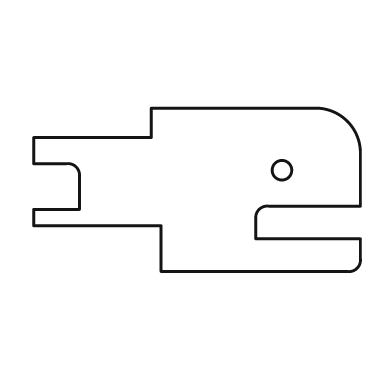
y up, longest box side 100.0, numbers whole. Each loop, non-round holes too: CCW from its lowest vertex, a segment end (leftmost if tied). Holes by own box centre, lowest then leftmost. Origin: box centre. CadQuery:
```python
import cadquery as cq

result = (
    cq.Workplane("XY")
    .moveTo(-11.0, -25.0)
    .lineTo(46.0, -25.0)
    .threePointArc((49.0, -24.0), (50.0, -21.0))
    .lineTo(50.0, -15.0)
    .lineTo(18.0, -15.0)
    .lineTo(18.0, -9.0)
    .threePointArc((19.0, -6.0), (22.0, -5.0))
    .lineTo(50.0, -5.0)
    .lineTo(50.0, 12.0)
    .threePointArc((46.0, 21.0), (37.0, 25.0))
    .lineTo(-14.0, 25.0)
    .lineTo(-14.0, 16.0)
    .lineTo(-50.0, 16.0)
    .lineTo(-50.0, 8.0)
    .lineTo(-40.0, 8.0)
    .threePointArc((-37.0, 7.0), (-36.0, 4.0))
    .lineTo(-36.0, -6.0)
    .lineTo(-50.0, -6.0)
    .lineTo(-50.0, -11.0)
    .lineTo(-11.0, -11.0)
    .close()
    .moveTo(26.0, 6.0)
    .circle(3.0)
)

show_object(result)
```